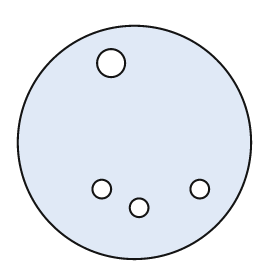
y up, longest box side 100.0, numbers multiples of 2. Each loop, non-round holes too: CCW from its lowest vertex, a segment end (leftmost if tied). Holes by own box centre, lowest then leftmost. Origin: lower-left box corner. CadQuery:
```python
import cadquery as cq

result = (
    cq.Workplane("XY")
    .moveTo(50.0, 50.0)
    .circle(50.0)
    .moveTo(52.0, 22.0)
    .circle(4.0)
    .moveTo(36.0, 30.0)
    .circle(4.0)
    .moveTo(78.0, 30.0)
    .circle(4.0)
    .moveTo(40.0, 84.0)
    .circle(6.0)
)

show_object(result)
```